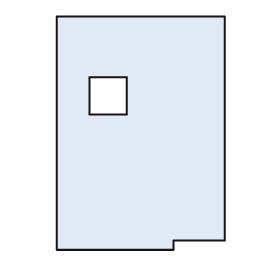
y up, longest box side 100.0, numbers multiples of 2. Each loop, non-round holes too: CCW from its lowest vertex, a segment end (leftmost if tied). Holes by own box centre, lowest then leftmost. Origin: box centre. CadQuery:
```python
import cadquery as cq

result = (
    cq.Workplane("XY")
    .moveTo(-36.0, -50.0)
    .lineTo(14.0, -50.0)
    .lineTo(14.0, -46.0)
    .lineTo(36.0, -46.0)
    .lineTo(36.0, 50.0)
    .lineTo(-36.0, 50.0)
    .close()
    .moveTo(-22.0, 8.0)
    .lineTo(-6.0, 8.0)
    .lineTo(-6.0, 24.0)
    .lineTo(-22.0, 24.0)
    .close()
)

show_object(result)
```